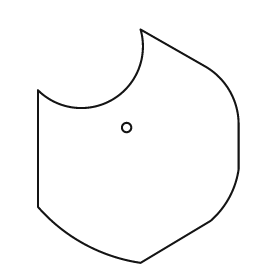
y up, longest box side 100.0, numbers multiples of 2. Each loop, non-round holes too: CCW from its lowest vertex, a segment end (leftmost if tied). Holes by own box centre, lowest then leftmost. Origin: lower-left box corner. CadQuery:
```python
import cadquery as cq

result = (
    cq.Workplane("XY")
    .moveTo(44.0, 0.0)
    .lineTo(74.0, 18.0)
    .threePointArc((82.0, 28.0), (86.0, 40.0))
    .lineTo(86.0, 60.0)
    .threePointArc((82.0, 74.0), (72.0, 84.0))
    .lineTo(44.0, 100.0)
    .threePointArc((32.0, 70.0), (0.0, 74.0))
    .lineTo(0.0, 24.0)
    .threePointArc((20.0, 8.0), (44.0, 0.0))
    .close()
    .moveTo(38.0, 58.0)
    .circle(2.0)
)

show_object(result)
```